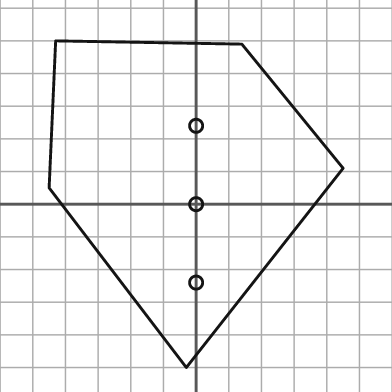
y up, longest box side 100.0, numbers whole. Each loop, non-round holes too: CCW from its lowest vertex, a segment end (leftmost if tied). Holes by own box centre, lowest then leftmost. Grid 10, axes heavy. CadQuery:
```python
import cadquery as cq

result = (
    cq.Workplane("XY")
    .moveTo(-3.0, -50.0)
    .lineTo(45.0, 11.0)
    .lineTo(14.0, 49.0)
    .lineTo(-43.0, 50.0)
    .lineTo(-45.0, 5.0)
    .close()
    .moveTo(0.0, -24.0)
    .circle(2.0)
    .moveTo(0.0, 0.0)
    .circle(2.0)
    .moveTo(0.0, 24.0)
    .circle(2.0)
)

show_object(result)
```